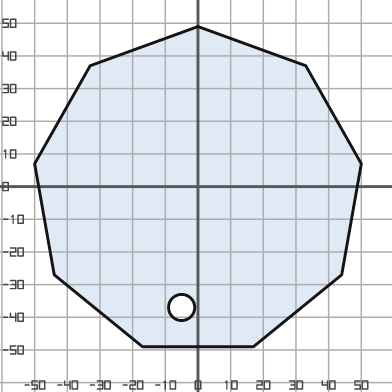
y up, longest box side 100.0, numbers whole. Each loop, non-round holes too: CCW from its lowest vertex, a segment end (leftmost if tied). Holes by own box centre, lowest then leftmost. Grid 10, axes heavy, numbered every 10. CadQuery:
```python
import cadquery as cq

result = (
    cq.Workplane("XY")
    .moveTo(-17.0, -49.0)
    .lineTo(17.0, -49.0)
    .lineTo(44.0, -27.0)
    .lineTo(50.0, 7.0)
    .lineTo(33.0, 37.0)
    .lineTo(0.0, 49.0)
    .lineTo(-33.0, 37.0)
    .lineTo(-50.0, 7.0)
    .lineTo(-44.0, -27.0)
    .close()
    .moveTo(-5.0, -37.0)
    .circle(4.0)
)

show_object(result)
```